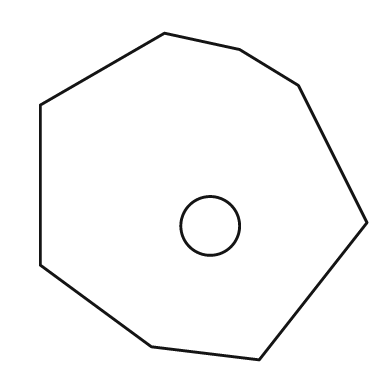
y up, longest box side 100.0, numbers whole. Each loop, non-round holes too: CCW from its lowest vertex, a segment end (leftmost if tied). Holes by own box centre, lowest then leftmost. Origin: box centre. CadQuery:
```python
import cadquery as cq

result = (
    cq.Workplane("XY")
    .moveTo(17.0, -50.0)
    .lineTo(50.0, -8.0)
    .lineTo(29.0, 34.0)
    .lineTo(11.0, 45.0)
    .lineTo(-12.0, 50.0)
    .lineTo(-50.0, 28.0)
    .lineTo(-50.0, -21.0)
    .lineTo(-16.0, -46.0)
    .close()
    .moveTo(2.0, -9.0)
    .circle(9.0)
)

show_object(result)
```